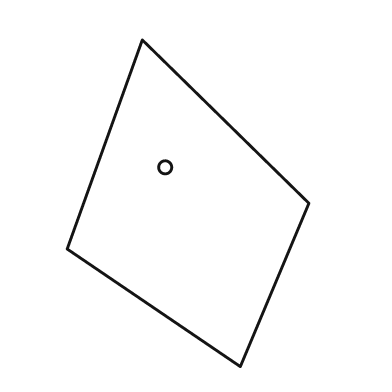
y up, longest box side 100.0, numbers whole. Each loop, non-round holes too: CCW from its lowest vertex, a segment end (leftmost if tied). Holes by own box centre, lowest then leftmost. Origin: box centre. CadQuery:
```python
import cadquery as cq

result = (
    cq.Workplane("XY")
    .moveTo(16.0, -50.0)
    .lineTo(37.0, 0.0)
    .lineTo(-14.0, 50.0)
    .lineTo(-37.0, -14.0)
    .close()
    .moveTo(-7.0, 11.0)
    .circle(2.0)
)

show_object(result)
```